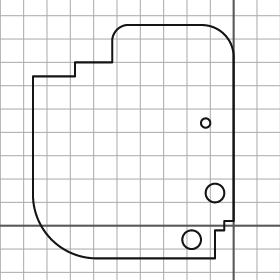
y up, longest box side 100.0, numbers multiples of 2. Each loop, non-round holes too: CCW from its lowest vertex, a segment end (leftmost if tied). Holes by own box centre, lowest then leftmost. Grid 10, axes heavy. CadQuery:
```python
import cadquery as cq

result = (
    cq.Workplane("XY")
    .moveTo(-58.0, -14.0)
    .lineTo(-8.0, -14.0)
    .lineTo(-8.0, -2.0)
    .lineTo(-4.0, -2.0)
    .lineTo(-4.0, 2.0)
    .lineTo(0.0, 2.0)
    .lineTo(0.0, 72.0)
    .threePointArc((-4.0, 82.0), (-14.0, 86.0))
    .lineTo(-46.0, 86.0)
    .threePointArc((-50.0, 84.0), (-52.0, 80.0))
    .lineTo(-52.0, 70.0)
    .lineTo(-68.0, 70.0)
    .lineTo(-68.0, 64.0)
    .lineTo(-86.0, 64.0)
    .lineTo(-86.0, 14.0)
    .threePointArc((-78.0, -6.0), (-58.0, -14.0))
    .close()
    .moveTo(-18.0, -6.0)
    .circle(4.0)
    .moveTo(-8.0, 14.0)
    .circle(4.0)
    .moveTo(-12.0, 44.0)
    .circle(2.0)
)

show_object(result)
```